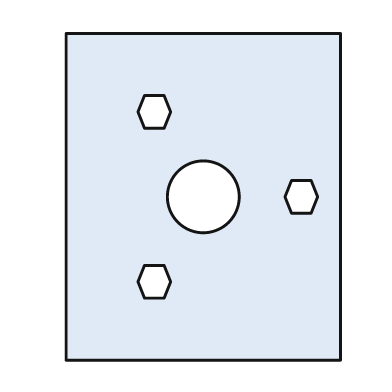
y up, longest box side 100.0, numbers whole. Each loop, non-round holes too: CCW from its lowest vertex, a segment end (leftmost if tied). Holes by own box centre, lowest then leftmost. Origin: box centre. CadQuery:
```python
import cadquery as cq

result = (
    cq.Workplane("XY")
    .moveTo(-42.0, -50.0)
    .lineTo(42.0, -50.0)
    .lineTo(42.0, 50.0)
    .lineTo(-42.0, 50.0)
    .close()
    .moveTo(-18.0, -31.0)
    .lineTo(-12.0, -31.0)
    .lineTo(-10.0, -26.0)
    .lineTo(-12.0, -21.0)
    .lineTo(-18.0, -21.0)
    .lineTo(-20.0, -26.0)
    .close()
    .moveTo(0.0, 0.0)
    .circle(11.0)
    .moveTo(27.0, -5.0)
    .lineTo(33.0, -5.0)
    .lineTo(35.0, 0.0)
    .lineTo(33.0, 5.0)
    .lineTo(27.0, 5.0)
    .lineTo(25.0, 0.0)
    .close()
    .moveTo(-18.0, 21.0)
    .lineTo(-12.0, 21.0)
    .lineTo(-10.0, 26.0)
    .lineTo(-12.0, 31.0)
    .lineTo(-18.0, 31.0)
    .lineTo(-20.0, 26.0)
    .close()
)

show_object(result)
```